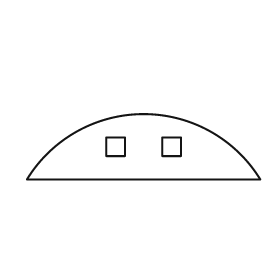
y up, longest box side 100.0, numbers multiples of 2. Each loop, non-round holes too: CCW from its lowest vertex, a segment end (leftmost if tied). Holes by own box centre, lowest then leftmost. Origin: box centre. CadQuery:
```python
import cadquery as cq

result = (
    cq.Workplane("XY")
    .moveTo(-50.0, -14.0)
    .lineTo(50.0, -14.0)
    .threePointArc((0.0, 14.0), (-50.0, -14.0))
    .close()
    .moveTo(-16.0, -4.0)
    .lineTo(-8.0, -4.0)
    .lineTo(-8.0, 4.0)
    .lineTo(-16.0, 4.0)
    .close()
    .moveTo(8.0, -4.0)
    .lineTo(16.0, -4.0)
    .lineTo(16.0, 4.0)
    .lineTo(8.0, 4.0)
    .close()
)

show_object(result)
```